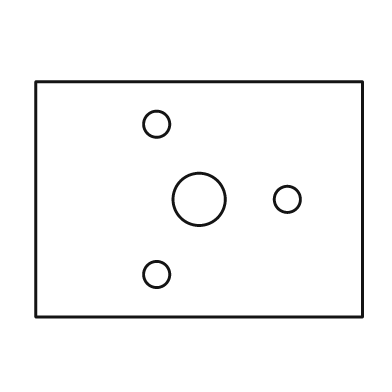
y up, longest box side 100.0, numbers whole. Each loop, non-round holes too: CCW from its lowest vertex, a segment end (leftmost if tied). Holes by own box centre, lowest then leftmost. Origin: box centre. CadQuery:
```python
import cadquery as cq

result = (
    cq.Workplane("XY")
    .moveTo(-50.0, -36.0)
    .lineTo(50.0, -36.0)
    .lineTo(50.0, 36.0)
    .lineTo(-50.0, 36.0)
    .close()
    .moveTo(-13.0, -23.0)
    .circle(4.0)
    .moveTo(0.0, 0.0)
    .circle(8.0)
    .moveTo(27.0, 0.0)
    .circle(4.0)
    .moveTo(-13.0, 23.0)
    .circle(4.0)
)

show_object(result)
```